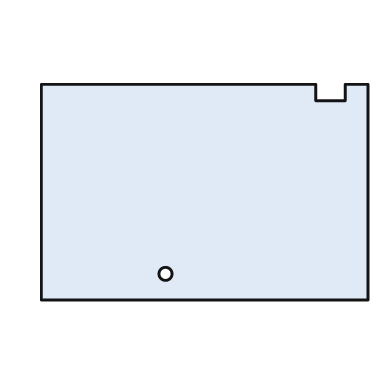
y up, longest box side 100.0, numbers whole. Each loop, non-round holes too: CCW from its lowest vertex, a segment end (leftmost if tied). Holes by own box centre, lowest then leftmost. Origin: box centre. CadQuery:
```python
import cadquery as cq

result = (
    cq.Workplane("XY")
    .moveTo(-50.0, -33.0)
    .lineTo(50.0, -33.0)
    .lineTo(50.0, 33.0)
    .lineTo(43.0, 33.0)
    .lineTo(43.0, 28.0)
    .lineTo(34.0, 28.0)
    .lineTo(34.0, 33.0)
    .lineTo(-50.0, 33.0)
    .close()
    .moveTo(-12.0, -25.0)
    .circle(2.0)
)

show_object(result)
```